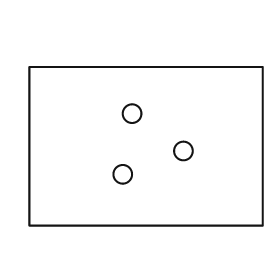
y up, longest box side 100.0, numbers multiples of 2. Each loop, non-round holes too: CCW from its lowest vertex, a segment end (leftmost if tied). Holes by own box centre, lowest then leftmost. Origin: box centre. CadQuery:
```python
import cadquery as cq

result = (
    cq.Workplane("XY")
    .moveTo(-50.0, -34.0)
    .lineTo(50.0, -34.0)
    .lineTo(50.0, 34.0)
    .lineTo(-50.0, 34.0)
    .close()
    .moveTo(-10.0, -12.0)
    .circle(4.0)
    .moveTo(16.0, -2.0)
    .circle(4.0)
    .moveTo(-6.0, 14.0)
    .circle(4.0)
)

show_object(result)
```